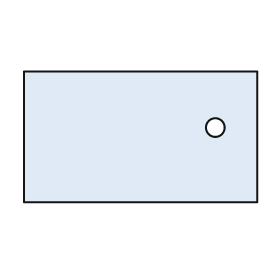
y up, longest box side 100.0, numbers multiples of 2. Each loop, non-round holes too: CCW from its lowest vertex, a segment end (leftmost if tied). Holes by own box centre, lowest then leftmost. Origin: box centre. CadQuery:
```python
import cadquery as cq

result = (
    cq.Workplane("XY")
    .moveTo(-50.0, -28.0)
    .lineTo(50.0, -28.0)
    .lineTo(50.0, 28.0)
    .lineTo(-50.0, 28.0)
    .close()
    .moveTo(32.0, 4.0)
    .circle(4.0)
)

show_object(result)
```